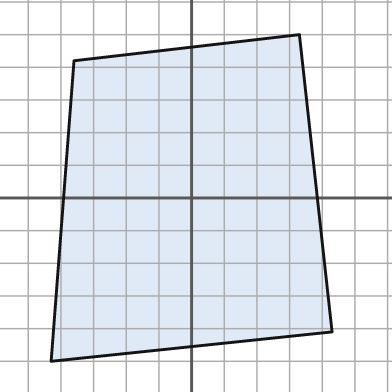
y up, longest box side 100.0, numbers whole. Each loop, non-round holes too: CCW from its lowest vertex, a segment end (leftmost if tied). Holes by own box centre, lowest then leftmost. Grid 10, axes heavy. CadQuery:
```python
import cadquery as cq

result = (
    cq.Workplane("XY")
    .moveTo(-43.0, -50.0)
    .lineTo(43.0, -41.0)
    .lineTo(33.0, 50.0)
    .lineTo(-36.0, 42.0)
    .close()
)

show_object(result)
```